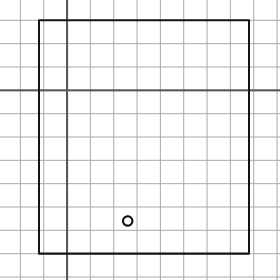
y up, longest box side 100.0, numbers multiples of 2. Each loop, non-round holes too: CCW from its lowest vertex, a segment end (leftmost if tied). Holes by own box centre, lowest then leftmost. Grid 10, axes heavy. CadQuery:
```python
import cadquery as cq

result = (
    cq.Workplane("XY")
    .moveTo(-12.0, -70.0)
    .lineTo(78.0, -70.0)
    .lineTo(78.0, 30.0)
    .lineTo(-12.0, 30.0)
    .close()
    .moveTo(26.0, -56.0)
    .circle(2.0)
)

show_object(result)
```